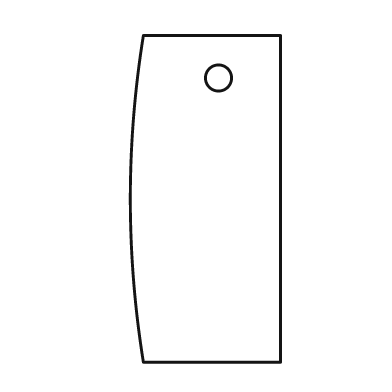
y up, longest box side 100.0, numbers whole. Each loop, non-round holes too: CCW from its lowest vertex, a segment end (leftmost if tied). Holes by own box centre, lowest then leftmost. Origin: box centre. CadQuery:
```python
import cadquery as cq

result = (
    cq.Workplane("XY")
    .moveTo(-19.0, -50.0)
    .lineTo(23.0, -50.0)
    .lineTo(23.0, 50.0)
    .lineTo(-19.0, 50.0)
    .threePointArc((-23.0, 0.0), (-19.0, -50.0))
    .close()
    .moveTo(4.0, 37.0)
    .circle(4.0)
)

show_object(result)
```